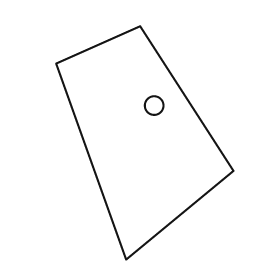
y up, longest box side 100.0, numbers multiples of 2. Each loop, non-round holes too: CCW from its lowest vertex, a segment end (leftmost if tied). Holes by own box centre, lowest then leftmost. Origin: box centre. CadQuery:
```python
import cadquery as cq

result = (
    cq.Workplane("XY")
    .moveTo(-8.0, -50.0)
    .lineTo(38.0, -12.0)
    .lineTo(-2.0, 50.0)
    .lineTo(-38.0, 34.0)
    .close()
    .moveTo(4.0, 16.0)
    .circle(4.0)
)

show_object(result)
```